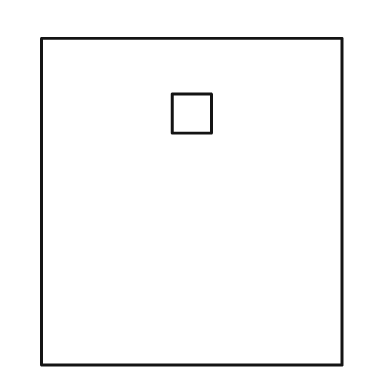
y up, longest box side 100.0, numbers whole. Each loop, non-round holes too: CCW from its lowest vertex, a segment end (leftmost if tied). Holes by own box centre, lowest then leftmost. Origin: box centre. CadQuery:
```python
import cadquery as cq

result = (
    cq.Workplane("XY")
    .moveTo(-46.0, -50.0)
    .lineTo(46.0, -50.0)
    .lineTo(46.0, 50.0)
    .lineTo(-46.0, 50.0)
    .close()
    .moveTo(-6.0, 21.0)
    .lineTo(6.0, 21.0)
    .lineTo(6.0, 33.0)
    .lineTo(-6.0, 33.0)
    .close()
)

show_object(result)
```